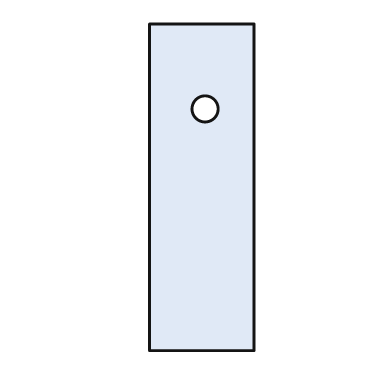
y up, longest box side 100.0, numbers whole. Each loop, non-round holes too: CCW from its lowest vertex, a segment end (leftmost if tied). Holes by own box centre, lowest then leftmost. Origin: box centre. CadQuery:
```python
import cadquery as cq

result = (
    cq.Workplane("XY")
    .moveTo(-16.0, -50.0)
    .lineTo(16.0, -50.0)
    .lineTo(16.0, 50.0)
    .lineTo(-16.0, 50.0)
    .close()
    .moveTo(1.0, 24.0)
    .circle(4.0)
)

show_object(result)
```